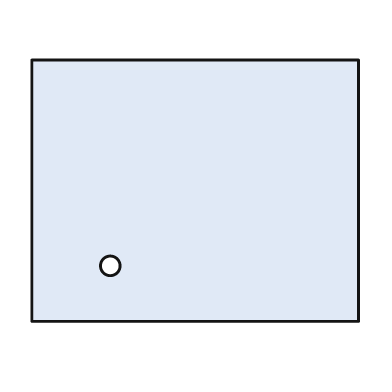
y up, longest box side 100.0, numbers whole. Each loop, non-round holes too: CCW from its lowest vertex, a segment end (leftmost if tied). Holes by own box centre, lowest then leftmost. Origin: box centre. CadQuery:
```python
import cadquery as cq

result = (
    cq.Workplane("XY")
    .moveTo(-50.0, -40.0)
    .lineTo(50.0, -40.0)
    .lineTo(50.0, 40.0)
    .lineTo(-50.0, 40.0)
    .close()
    .moveTo(-26.0, -23.0)
    .circle(3.0)
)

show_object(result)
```